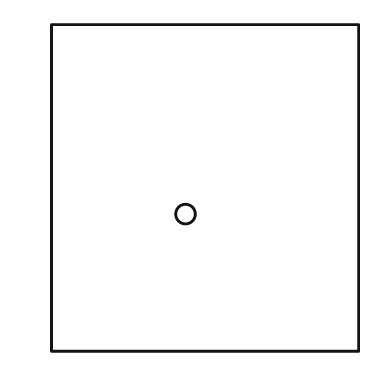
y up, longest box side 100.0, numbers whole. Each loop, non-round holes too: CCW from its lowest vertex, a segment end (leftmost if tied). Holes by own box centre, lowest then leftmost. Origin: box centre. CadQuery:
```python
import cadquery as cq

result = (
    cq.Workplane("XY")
    .moveTo(-47.0, -50.0)
    .lineTo(47.0, -50.0)
    .lineTo(47.0, 50.0)
    .lineTo(-47.0, 50.0)
    .close()
    .moveTo(-6.0, -8.0)
    .circle(3.0)
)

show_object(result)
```